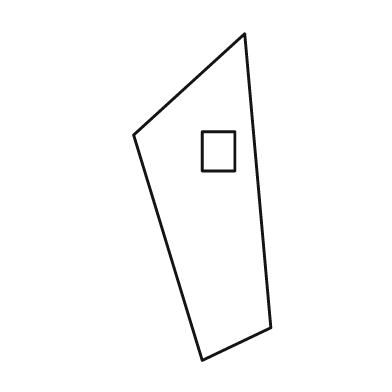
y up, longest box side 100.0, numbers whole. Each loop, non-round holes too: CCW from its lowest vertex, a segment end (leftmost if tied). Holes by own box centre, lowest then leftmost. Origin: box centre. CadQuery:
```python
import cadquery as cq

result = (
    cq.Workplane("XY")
    .moveTo(0.0, -50.0)
    .lineTo(21.0, -40.0)
    .lineTo(13.0, 50.0)
    .lineTo(-21.0, 19.0)
    .close()
    .moveTo(0.0, 8.0)
    .lineTo(10.0, 8.0)
    .lineTo(10.0, 20.0)
    .lineTo(0.0, 20.0)
    .close()
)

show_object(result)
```